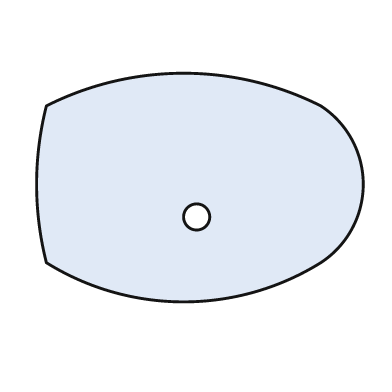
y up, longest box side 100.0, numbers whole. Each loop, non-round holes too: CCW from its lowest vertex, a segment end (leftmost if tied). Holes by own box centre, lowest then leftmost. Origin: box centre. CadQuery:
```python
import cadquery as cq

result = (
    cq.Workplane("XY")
    .moveTo(-47.0, -23.0)
    .threePointArc((-5.0, -35.0), (37.0, -23.0))
    .threePointArc((50.0, 1.0), (37.0, 25.0))
    .threePointArc((-5.0, 35.0), (-47.0, 25.0))
    .threePointArc((-50.0, 1.0), (-47.0, -23.0))
    .close()
    .moveTo(-1.0, -9.0)
    .circle(4.0)
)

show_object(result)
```